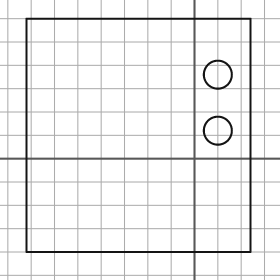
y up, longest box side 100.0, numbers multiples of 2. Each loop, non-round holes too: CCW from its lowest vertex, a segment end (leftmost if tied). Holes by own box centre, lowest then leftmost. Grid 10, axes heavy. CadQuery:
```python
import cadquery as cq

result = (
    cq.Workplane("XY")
    .moveTo(-72.0, -40.0)
    .lineTo(24.0, -40.0)
    .lineTo(24.0, 60.0)
    .lineTo(-72.0, 60.0)
    .close()
    .moveTo(10.0, 12.0)
    .circle(6.0)
    .moveTo(10.0, 36.0)
    .circle(6.0)
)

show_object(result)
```